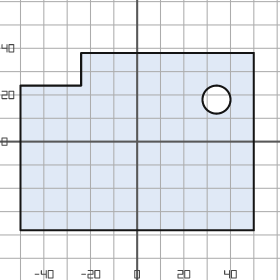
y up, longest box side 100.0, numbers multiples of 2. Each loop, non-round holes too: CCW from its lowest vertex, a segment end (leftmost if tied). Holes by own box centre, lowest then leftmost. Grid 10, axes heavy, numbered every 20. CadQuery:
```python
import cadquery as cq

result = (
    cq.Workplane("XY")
    .moveTo(-50.0, -38.0)
    .lineTo(50.0, -38.0)
    .lineTo(50.0, 38.0)
    .lineTo(-24.0, 38.0)
    .lineTo(-24.0, 24.0)
    .lineTo(-50.0, 24.0)
    .close()
    .moveTo(34.0, 18.0)
    .circle(6.0)
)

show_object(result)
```